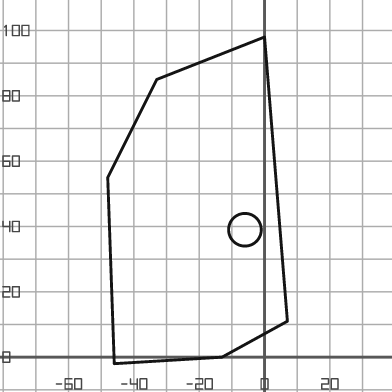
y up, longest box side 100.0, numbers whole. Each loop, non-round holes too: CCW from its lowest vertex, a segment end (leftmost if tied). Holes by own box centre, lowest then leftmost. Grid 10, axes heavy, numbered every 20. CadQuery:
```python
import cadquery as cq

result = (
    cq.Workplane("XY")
    .moveTo(-46.0, -2.0)
    .lineTo(-13.0, 0.0)
    .lineTo(7.0, 11.0)
    .lineTo(0.0, 98.0)
    .lineTo(-33.0, 85.0)
    .lineTo(-48.0, 55.0)
    .close()
    .moveTo(-6.0, 39.0)
    .circle(5.0)
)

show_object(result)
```